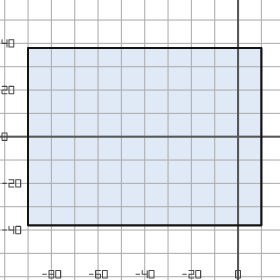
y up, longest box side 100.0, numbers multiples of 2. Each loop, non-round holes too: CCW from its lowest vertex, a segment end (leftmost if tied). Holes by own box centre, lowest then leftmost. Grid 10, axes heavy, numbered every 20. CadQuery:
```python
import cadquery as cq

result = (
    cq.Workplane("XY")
    .moveTo(-90.0, -38.0)
    .lineTo(10.0, -38.0)
    .lineTo(10.0, 38.0)
    .lineTo(-90.0, 38.0)
    .close()
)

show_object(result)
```